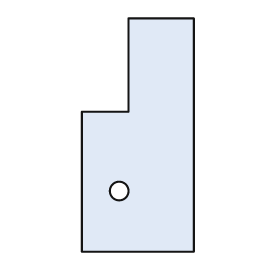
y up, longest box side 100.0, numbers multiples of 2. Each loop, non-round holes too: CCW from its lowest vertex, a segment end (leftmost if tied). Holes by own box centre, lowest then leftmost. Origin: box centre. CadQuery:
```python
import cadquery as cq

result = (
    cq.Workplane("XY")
    .moveTo(-24.0, -50.0)
    .lineTo(24.0, -50.0)
    .lineTo(24.0, 50.0)
    .lineTo(-4.0, 50.0)
    .lineTo(-4.0, 10.0)
    .lineTo(-24.0, 10.0)
    .close()
    .moveTo(-8.0, -24.0)
    .circle(4.0)
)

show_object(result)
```